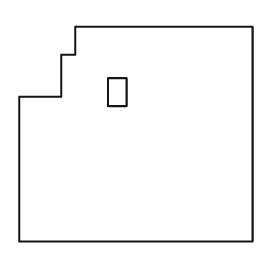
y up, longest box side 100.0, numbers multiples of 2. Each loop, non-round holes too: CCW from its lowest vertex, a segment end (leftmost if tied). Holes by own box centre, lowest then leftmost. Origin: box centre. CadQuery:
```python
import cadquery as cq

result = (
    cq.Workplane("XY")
    .moveTo(-50.0, -46.0)
    .lineTo(50.0, -46.0)
    .lineTo(50.0, 46.0)
    .lineTo(-26.0, 46.0)
    .lineTo(-26.0, 34.0)
    .lineTo(-32.0, 34.0)
    .lineTo(-32.0, 16.0)
    .lineTo(-50.0, 16.0)
    .close()
    .moveTo(-12.0, 12.0)
    .lineTo(-4.0, 12.0)
    .lineTo(-4.0, 24.0)
    .lineTo(-12.0, 24.0)
    .close()
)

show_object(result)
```